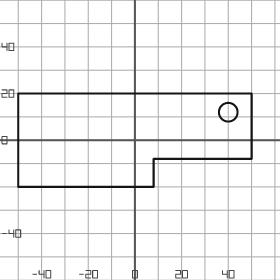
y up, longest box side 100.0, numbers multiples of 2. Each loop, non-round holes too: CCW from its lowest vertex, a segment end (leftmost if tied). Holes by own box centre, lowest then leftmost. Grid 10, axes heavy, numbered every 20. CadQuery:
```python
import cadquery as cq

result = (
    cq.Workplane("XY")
    .moveTo(-50.0, -20.0)
    .lineTo(8.0, -20.0)
    .lineTo(8.0, -8.0)
    .lineTo(50.0, -8.0)
    .lineTo(50.0, 20.0)
    .lineTo(-50.0, 20.0)
    .close()
    .moveTo(40.0, 12.0)
    .circle(4.0)
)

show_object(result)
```